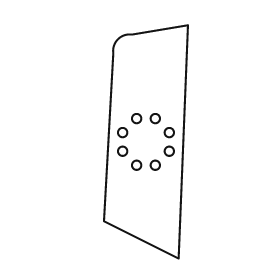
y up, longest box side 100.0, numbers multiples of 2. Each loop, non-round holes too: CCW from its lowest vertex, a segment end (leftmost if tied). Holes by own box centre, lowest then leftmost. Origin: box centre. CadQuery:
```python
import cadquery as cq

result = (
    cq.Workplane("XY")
    .moveTo(14.0, -50.0)
    .lineTo(18.0, 50.0)
    .lineTo(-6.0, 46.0)
    .threePointArc((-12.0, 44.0), (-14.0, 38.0))
    .lineTo(-18.0, -34.0)
    .close()
    .moveTo(-4.0, -10.0)
    .circle(2.0)
    .moveTo(4.0, -10.0)
    .circle(2.0)
    .moveTo(-10.0, -4.0)
    .circle(2.0)
    .moveTo(10.0, -4.0)
    .circle(2.0)
    .moveTo(-10.0, 4.0)
    .circle(2.0)
    .moveTo(10.0, 4.0)
    .circle(2.0)
    .moveTo(-4.0, 10.0)
    .circle(2.0)
    .moveTo(4.0, 10.0)
    .circle(2.0)
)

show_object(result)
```